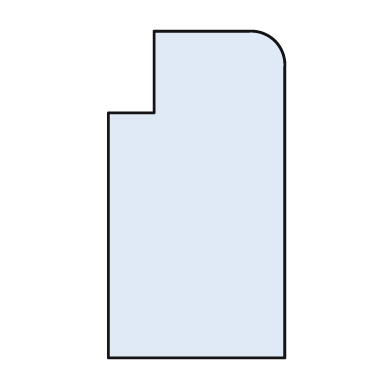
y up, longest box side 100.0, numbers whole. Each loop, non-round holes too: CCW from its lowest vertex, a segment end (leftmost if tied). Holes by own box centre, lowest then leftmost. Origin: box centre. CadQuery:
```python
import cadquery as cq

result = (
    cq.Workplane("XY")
    .moveTo(-27.0, -50.0)
    .lineTo(27.0, -50.0)
    .lineTo(27.0, 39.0)
    .threePointArc((24.0, 47.0), (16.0, 50.0))
    .lineTo(-13.0, 50.0)
    .lineTo(-13.0, 25.0)
    .lineTo(-27.0, 25.0)
    .close()
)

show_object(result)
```